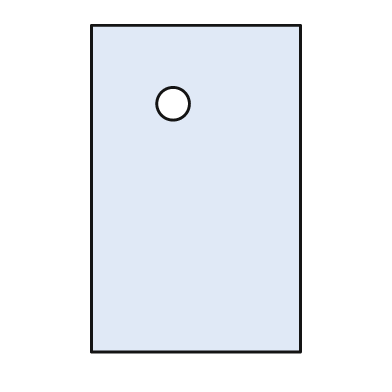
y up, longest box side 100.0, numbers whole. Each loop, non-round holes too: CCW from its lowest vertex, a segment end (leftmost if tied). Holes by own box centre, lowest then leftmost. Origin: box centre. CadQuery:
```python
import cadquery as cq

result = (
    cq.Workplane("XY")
    .moveTo(-32.0, -50.0)
    .lineTo(32.0, -50.0)
    .lineTo(32.0, 50.0)
    .lineTo(-32.0, 50.0)
    .close()
    .moveTo(-7.0, 26.0)
    .circle(5.0)
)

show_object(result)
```